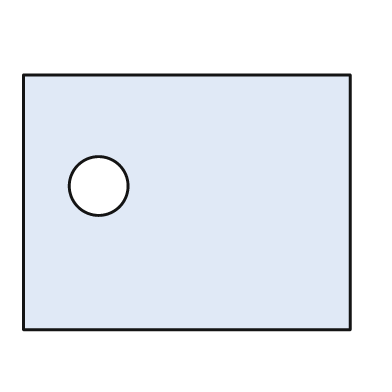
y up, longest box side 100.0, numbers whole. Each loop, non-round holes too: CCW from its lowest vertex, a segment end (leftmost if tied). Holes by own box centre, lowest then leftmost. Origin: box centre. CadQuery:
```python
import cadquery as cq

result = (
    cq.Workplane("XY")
    .moveTo(-50.0, -39.0)
    .lineTo(50.0, -39.0)
    .lineTo(50.0, 39.0)
    .lineTo(-50.0, 39.0)
    .close()
    .moveTo(-27.0, 5.0)
    .circle(9.0)
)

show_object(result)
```